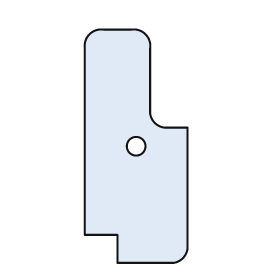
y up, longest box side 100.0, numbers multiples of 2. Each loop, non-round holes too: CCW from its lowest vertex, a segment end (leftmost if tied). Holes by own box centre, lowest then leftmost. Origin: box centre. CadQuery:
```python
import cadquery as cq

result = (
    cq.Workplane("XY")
    .moveTo(-8.0, -50.0)
    .lineTo(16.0, -50.0)
    .threePointArc((20.0, -48.0), (22.0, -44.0))
    .lineTo(22.0, 8.0)
    .lineTo(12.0, 8.0)
    .threePointArc((8.0, 10.0), (6.0, 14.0))
    .lineTo(6.0, 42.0)
    .threePointArc((4.0, 48.0), (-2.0, 50.0))
    .lineTo(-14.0, 50.0)
    .threePointArc((-20.0, 48.0), (-22.0, 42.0))
    .lineTo(-22.0, -38.0)
    .lineTo(-8.0, -38.0)
    .close()
    .moveTo(0.0, 0.0)
    .circle(4.0)
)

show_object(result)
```